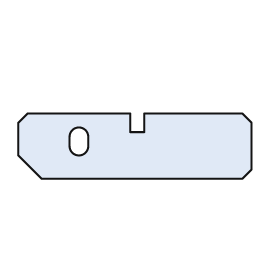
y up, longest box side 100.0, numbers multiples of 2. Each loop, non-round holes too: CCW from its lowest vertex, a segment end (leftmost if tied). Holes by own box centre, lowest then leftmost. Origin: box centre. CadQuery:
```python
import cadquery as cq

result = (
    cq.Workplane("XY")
    .moveTo(-40.0, -14.0)
    .lineTo(46.0, -14.0)
    .lineTo(50.0, -10.0)
    .lineTo(50.0, 10.0)
    .lineTo(46.0, 14.0)
    .lineTo(4.0, 14.0)
    .lineTo(4.0, 6.0)
    .lineTo(-2.0, 6.0)
    .lineTo(-2.0, 14.0)
    .lineTo(-46.0, 14.0)
    .lineTo(-50.0, 10.0)
    .lineTo(-50.0, -4.0)
    .close()
    .moveTo(-28.0, 0.0)
    .threePointArc((-24.0, -4.0), (-20.0, 0.0))
    .lineTo(-20.0, 4.0)
    .threePointArc((-24.0, 8.0), (-28.0, 4.0))
    .close()
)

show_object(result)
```